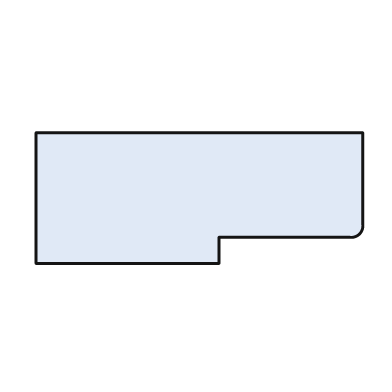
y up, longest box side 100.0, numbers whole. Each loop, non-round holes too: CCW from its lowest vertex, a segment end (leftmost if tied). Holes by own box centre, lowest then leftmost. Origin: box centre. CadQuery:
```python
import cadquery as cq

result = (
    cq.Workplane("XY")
    .moveTo(-50.0, -20.0)
    .lineTo(6.0, -20.0)
    .lineTo(6.0, -12.0)
    .lineTo(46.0, -12.0)
    .threePointArc((49.0, -11.0), (50.0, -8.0))
    .lineTo(50.0, 20.0)
    .lineTo(-50.0, 20.0)
    .close()
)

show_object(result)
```